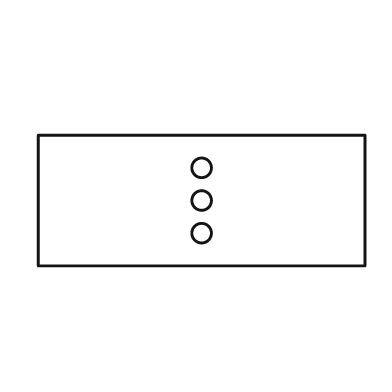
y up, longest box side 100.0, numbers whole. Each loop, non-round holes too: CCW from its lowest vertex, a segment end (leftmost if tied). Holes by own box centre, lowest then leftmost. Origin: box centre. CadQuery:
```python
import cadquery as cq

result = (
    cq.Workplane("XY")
    .moveTo(-50.0, -20.0)
    .lineTo(50.0, -20.0)
    .lineTo(50.0, 20.0)
    .lineTo(-50.0, 20.0)
    .close()
    .moveTo(0.0, -10.0)
    .circle(3.0)
    .moveTo(0.0, 0.0)
    .circle(3.0)
    .moveTo(0.0, 10.0)
    .circle(3.0)
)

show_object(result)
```